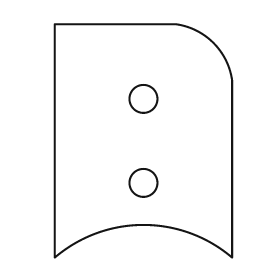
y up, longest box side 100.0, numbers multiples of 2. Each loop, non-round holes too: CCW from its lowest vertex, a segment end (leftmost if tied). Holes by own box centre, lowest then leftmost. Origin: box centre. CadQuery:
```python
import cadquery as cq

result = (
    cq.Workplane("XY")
    .moveTo(-38.0, -50.0)
    .threePointArc((0.0, -36.0), (38.0, -50.0))
    .lineTo(38.0, 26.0)
    .threePointArc((30.0, 42.0), (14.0, 50.0))
    .lineTo(-38.0, 50.0)
    .close()
    .moveTo(0.0, -18.0)
    .circle(6.0)
    .moveTo(0.0, 18.0)
    .circle(6.0)
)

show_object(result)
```